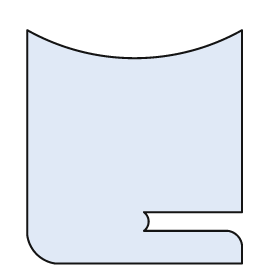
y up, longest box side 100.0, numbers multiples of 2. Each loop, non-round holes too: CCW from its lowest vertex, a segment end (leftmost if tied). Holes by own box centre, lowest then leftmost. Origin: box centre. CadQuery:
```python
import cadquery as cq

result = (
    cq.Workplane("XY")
    .moveTo(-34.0, -50.0)
    .lineTo(46.0, -50.0)
    .lineTo(46.0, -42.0)
    .threePointArc((44.0, -38.0), (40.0, -36.0))
    .lineTo(4.0, -36.0)
    .threePointArc((6.0, -32.0), (4.0, -28.0))
    .lineTo(46.0, -28.0)
    .lineTo(46.0, 50.0)
    .threePointArc((0.0, 38.0), (-46.0, 50.0))
    .lineTo(-46.0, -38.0)
    .threePointArc((-42.0, -46.0), (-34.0, -50.0))
    .close()
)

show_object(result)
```